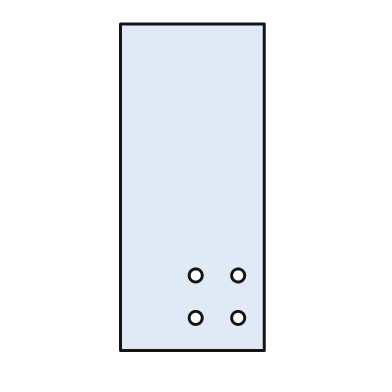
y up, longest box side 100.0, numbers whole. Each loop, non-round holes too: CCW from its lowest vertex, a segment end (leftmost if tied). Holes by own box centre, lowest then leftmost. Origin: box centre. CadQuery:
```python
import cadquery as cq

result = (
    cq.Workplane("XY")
    .moveTo(-22.0, -50.0)
    .lineTo(22.0, -50.0)
    .lineTo(22.0, 50.0)
    .lineTo(-22.0, 50.0)
    .close()
    .moveTo(1.0, -40.0)
    .circle(2.0)
    .moveTo(14.0, -40.0)
    .circle(2.0)
    .moveTo(1.0, -27.0)
    .circle(2.0)
    .moveTo(14.0, -27.0)
    .circle(2.0)
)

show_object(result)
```